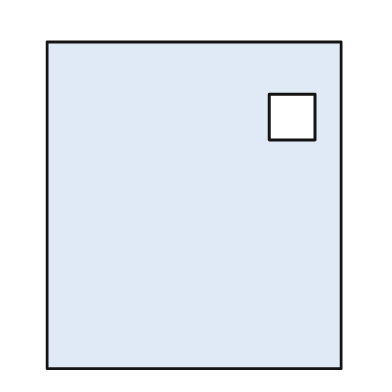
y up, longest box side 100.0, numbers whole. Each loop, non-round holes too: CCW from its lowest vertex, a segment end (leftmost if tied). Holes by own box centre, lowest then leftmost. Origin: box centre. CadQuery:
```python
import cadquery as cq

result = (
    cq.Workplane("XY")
    .moveTo(-45.0, -50.0)
    .lineTo(45.0, -50.0)
    .lineTo(45.0, 50.0)
    .lineTo(-45.0, 50.0)
    .close()
    .moveTo(23.0, 20.0)
    .lineTo(37.0, 20.0)
    .lineTo(37.0, 34.0)
    .lineTo(23.0, 34.0)
    .close()
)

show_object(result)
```